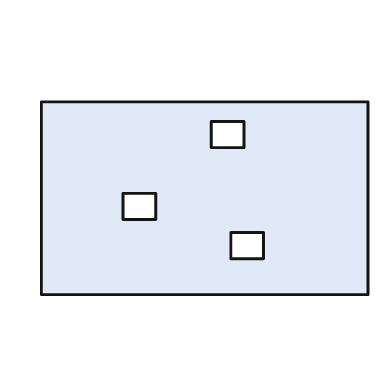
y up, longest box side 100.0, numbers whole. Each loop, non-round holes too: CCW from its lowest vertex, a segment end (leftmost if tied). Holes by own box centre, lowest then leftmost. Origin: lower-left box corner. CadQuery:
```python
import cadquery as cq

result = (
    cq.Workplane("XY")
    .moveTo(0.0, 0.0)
    .lineTo(100.0, 0.0)
    .lineTo(100.0, 59.0)
    .lineTo(0.0, 59.0)
    .close()
    .moveTo(58.0, 11.0)
    .lineTo(68.0, 11.0)
    .lineTo(68.0, 19.0)
    .lineTo(58.0, 19.0)
    .close()
    .moveTo(25.0, 23.0)
    .lineTo(35.0, 23.0)
    .lineTo(35.0, 31.0)
    .lineTo(25.0, 31.0)
    .close()
    .moveTo(52.0, 45.0)
    .lineTo(62.0, 45.0)
    .lineTo(62.0, 53.0)
    .lineTo(52.0, 53.0)
    .close()
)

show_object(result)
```